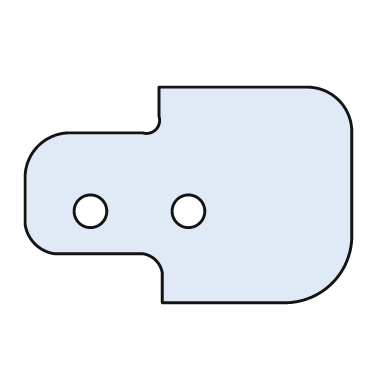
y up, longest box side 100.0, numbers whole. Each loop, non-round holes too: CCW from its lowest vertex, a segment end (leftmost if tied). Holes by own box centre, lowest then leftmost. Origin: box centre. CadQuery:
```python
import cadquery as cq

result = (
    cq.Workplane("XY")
    .moveTo(-8.0, -33.0)
    .lineTo(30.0, -33.0)
    .threePointArc((44.0, -27.0), (50.0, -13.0))
    .lineTo(50.0, 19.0)
    .threePointArc((46.0, 29.0), (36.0, 33.0))
    .lineTo(-9.0, 33.0)
    .lineTo(-9.0, 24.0)
    .threePointArc((-10.0, 20.0), (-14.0, 19.0))
    .lineTo(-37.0, 19.0)
    .threePointArc((-46.0, 15.0), (-50.0, 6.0))
    .lineTo(-50.0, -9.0)
    .threePointArc((-47.0, -15.0), (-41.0, -18.0))
    .lineTo(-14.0, -18.0)
    .threePointArc((-10.0, -20.0), (-8.0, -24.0))
    .close()
    .moveTo(-30.0, -5.0)
    .circle(5.0)
    .moveTo(0.0, -5.0)
    .circle(5.0)
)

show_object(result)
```